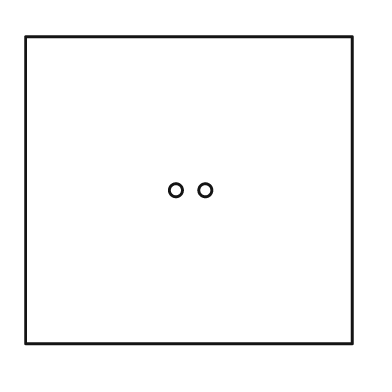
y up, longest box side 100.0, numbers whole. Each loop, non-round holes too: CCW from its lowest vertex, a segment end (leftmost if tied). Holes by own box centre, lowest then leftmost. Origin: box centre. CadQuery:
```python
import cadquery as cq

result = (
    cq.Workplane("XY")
    .moveTo(-50.0, -47.0)
    .lineTo(50.0, -47.0)
    .lineTo(50.0, 47.0)
    .lineTo(-50.0, 47.0)
    .close()
    .moveTo(-4.0, 0.0)
    .circle(2.0)
    .moveTo(5.0, 0.0)
    .circle(2.0)
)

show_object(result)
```